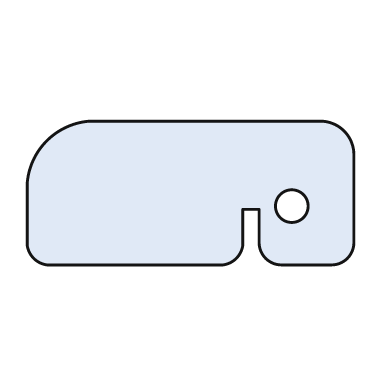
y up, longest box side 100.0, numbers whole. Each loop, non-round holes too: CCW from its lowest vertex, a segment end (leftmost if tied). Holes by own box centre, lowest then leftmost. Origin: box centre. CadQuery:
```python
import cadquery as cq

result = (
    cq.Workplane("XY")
    .moveTo(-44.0, -22.0)
    .lineTo(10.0, -22.0)
    .threePointArc((14.0, -20.0), (16.0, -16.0))
    .lineTo(16.0, -5.0)
    .lineTo(21.0, -5.0)
    .lineTo(21.0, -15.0)
    .threePointArc((23.0, -20.0), (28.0, -22.0))
    .lineTo(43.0, -22.0)
    .threePointArc((48.0, -20.0), (50.0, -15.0))
    .lineTo(50.0, 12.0)
    .threePointArc((47.0, 19.0), (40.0, 22.0))
    .lineTo(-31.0, 22.0)
    .threePointArc((-44.0, 16.0), (-50.0, 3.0))
    .lineTo(-50.0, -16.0)
    .threePointArc((-48.0, -20.0), (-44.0, -22.0))
    .close()
    .moveTo(31.0, -4.0)
    .circle(5.0)
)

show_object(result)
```